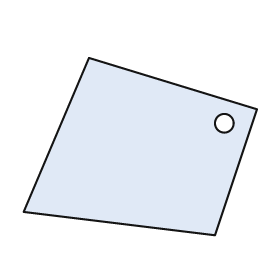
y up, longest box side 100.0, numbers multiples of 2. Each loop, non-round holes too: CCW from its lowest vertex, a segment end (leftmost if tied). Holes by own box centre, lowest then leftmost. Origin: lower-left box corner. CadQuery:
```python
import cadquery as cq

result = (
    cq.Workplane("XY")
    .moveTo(82.0, 0.0)
    .lineTo(100.0, 54.0)
    .lineTo(28.0, 76.0)
    .lineTo(0.0, 10.0)
    .close()
    .moveTo(86.0, 48.0)
    .circle(4.0)
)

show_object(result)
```